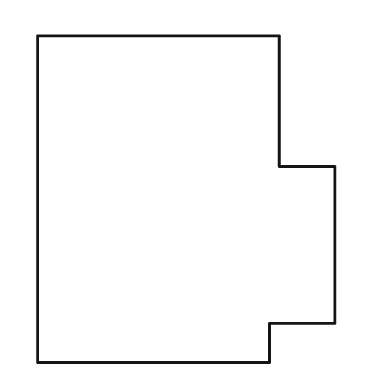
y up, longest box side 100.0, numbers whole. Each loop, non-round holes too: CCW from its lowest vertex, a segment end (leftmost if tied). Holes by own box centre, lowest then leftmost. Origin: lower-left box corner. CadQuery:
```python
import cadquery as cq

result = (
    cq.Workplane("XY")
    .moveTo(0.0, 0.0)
    .lineTo(71.0, 0.0)
    .lineTo(71.0, 12.0)
    .lineTo(91.0, 12.0)
    .lineTo(91.0, 60.0)
    .lineTo(74.0, 60.0)
    .lineTo(74.0, 100.0)
    .lineTo(0.0, 100.0)
    .close()
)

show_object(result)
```